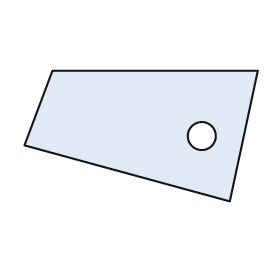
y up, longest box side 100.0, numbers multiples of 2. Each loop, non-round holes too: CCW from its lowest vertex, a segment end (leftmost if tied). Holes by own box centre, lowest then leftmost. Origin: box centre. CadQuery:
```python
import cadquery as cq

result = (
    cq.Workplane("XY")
    .moveTo(38.0, -28.0)
    .lineTo(50.0, 28.0)
    .lineTo(-38.0, 28.0)
    .lineTo(-50.0, -4.0)
    .close()
    .moveTo(26.0, 0.0)
    .circle(6.0)
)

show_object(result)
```